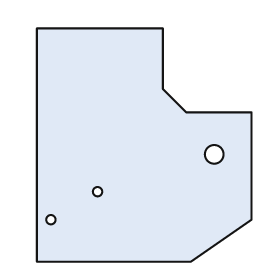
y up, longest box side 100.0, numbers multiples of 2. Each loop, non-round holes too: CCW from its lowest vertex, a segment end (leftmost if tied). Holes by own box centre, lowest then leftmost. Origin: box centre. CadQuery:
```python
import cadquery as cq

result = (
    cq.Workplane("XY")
    .moveTo(-46.0, -50.0)
    .lineTo(20.0, -50.0)
    .lineTo(46.0, -32.0)
    .lineTo(46.0, 14.0)
    .lineTo(18.0, 14.0)
    .lineTo(8.0, 24.0)
    .lineTo(8.0, 50.0)
    .lineTo(-46.0, 50.0)
    .close()
    .moveTo(-40.0, -32.0)
    .circle(2.0)
    .moveTo(-20.0, -20.0)
    .circle(2.0)
    .moveTo(30.0, -4.0)
    .circle(4.0)
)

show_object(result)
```